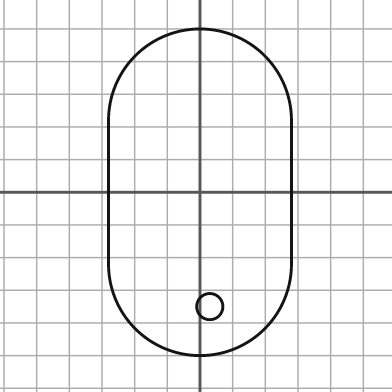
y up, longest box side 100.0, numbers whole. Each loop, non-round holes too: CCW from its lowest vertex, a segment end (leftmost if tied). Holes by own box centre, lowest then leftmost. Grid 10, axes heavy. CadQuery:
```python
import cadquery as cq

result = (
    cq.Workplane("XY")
    .moveTo(-28.0, -22.0)
    .threePointArc((0.0, -50.0), (28.0, -22.0))
    .lineTo(28.0, 22.0)
    .threePointArc((0.0, 50.0), (-28.0, 22.0))
    .close()
    .moveTo(3.0, -35.0)
    .circle(4.0)
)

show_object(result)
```